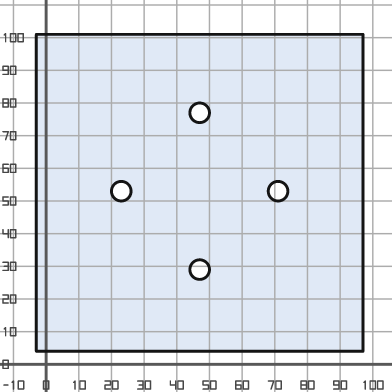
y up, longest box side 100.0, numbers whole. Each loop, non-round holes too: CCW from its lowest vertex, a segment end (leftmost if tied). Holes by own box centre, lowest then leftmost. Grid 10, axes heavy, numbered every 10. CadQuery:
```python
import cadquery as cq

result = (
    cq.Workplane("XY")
    .moveTo(-3.0, 4.0)
    .lineTo(97.0, 4.0)
    .lineTo(97.0, 101.0)
    .lineTo(-3.0, 101.0)
    .close()
    .moveTo(47.0, 29.0)
    .circle(3.0)
    .moveTo(23.0, 53.0)
    .circle(3.0)
    .moveTo(71.0, 53.0)
    .circle(3.0)
    .moveTo(47.0, 77.0)
    .circle(3.0)
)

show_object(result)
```